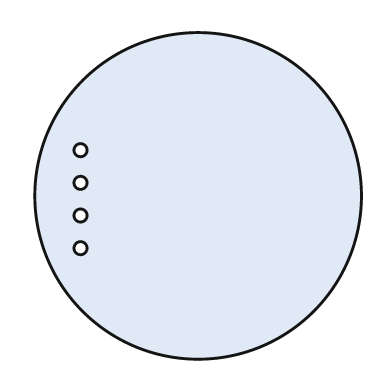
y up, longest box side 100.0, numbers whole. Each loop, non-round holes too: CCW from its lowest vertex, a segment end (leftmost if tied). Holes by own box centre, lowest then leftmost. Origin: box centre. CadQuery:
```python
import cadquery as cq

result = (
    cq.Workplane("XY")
    .moveTo(0.0, 0.0)
    .circle(50.0)
    .moveTo(-36.0, -16.0)
    .circle(2.0)
    .moveTo(-36.0, -6.0)
    .circle(2.0)
    .moveTo(-36.0, 4.0)
    .circle(2.0)
    .moveTo(-36.0, 14.0)
    .circle(2.0)
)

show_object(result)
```